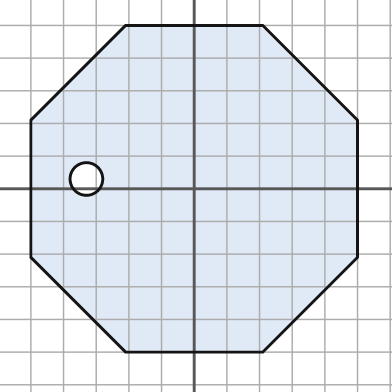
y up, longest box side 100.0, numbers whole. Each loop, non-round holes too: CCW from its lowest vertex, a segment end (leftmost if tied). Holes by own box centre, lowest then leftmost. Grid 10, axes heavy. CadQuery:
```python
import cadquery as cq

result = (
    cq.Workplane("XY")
    .moveTo(-21.0, -50.0)
    .lineTo(21.0, -50.0)
    .lineTo(50.0, -21.0)
    .lineTo(50.0, 21.0)
    .lineTo(21.0, 50.0)
    .lineTo(-21.0, 50.0)
    .lineTo(-50.0, 21.0)
    .lineTo(-50.0, -21.0)
    .close()
    .moveTo(-33.0, 3.0)
    .circle(5.0)
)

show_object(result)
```